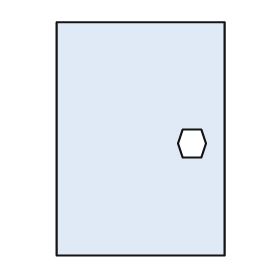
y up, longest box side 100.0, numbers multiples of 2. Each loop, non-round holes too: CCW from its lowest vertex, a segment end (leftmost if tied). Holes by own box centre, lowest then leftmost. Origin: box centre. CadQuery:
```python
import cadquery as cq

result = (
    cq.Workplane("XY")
    .moveTo(-36.0, -50.0)
    .lineTo(36.0, -50.0)
    .lineTo(36.0, 50.0)
    .lineTo(-36.0, 50.0)
    .close()
    .moveTo(18.0, -8.0)
    .lineTo(26.0, -8.0)
    .lineTo(28.0, -2.0)
    .lineTo(26.0, 4.0)
    .lineTo(18.0, 4.0)
    .lineTo(16.0, -2.0)
    .close()
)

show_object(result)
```